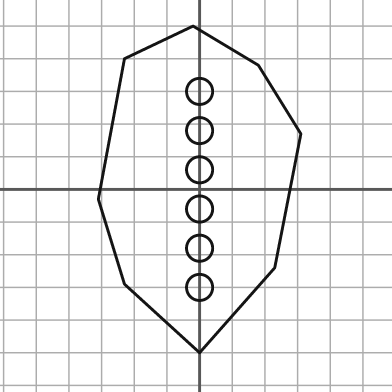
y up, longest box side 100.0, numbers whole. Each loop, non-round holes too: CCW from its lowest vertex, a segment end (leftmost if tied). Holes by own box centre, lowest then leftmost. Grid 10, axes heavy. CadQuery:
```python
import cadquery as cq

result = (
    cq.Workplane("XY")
    .moveTo(0.0, -50.0)
    .lineTo(23.0, -24.0)
    .lineTo(31.0, 17.0)
    .lineTo(18.0, 38.0)
    .lineTo(-2.0, 50.0)
    .lineTo(-23.0, 40.0)
    .lineTo(-31.0, -3.0)
    .lineTo(-23.0, -29.0)
    .close()
    .moveTo(0.0, -30.0)
    .circle(4.0)
    .moveTo(0.0, -18.0)
    .circle(4.0)
    .moveTo(0.0, -6.0)
    .circle(4.0)
    .moveTo(0.0, 6.0)
    .circle(4.0)
    .moveTo(0.0, 18.0)
    .circle(4.0)
    .moveTo(0.0, 30.0)
    .circle(4.0)
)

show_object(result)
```